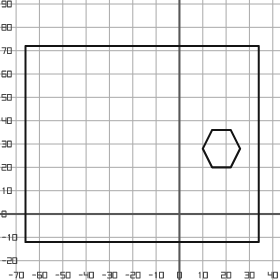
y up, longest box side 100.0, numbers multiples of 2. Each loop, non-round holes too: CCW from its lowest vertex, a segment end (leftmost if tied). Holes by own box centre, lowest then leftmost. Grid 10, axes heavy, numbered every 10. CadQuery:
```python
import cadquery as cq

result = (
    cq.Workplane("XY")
    .moveTo(-66.0, -12.0)
    .lineTo(34.0, -12.0)
    .lineTo(34.0, 72.0)
    .lineTo(-66.0, 72.0)
    .close()
    .moveTo(14.0, 20.0)
    .lineTo(22.0, 20.0)
    .lineTo(26.0, 28.0)
    .lineTo(22.0, 36.0)
    .lineTo(14.0, 36.0)
    .lineTo(10.0, 28.0)
    .close()
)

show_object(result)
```